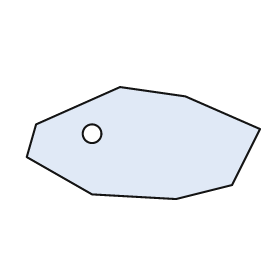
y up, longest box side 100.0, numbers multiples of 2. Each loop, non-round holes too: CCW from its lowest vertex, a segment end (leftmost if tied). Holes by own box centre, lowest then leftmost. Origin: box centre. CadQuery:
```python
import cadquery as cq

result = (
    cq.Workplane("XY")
    .moveTo(14.0, -24.0)
    .lineTo(38.0, -18.0)
    .lineTo(50.0, 6.0)
    .lineTo(18.0, 20.0)
    .lineTo(-10.0, 24.0)
    .lineTo(-46.0, 8.0)
    .lineTo(-50.0, -6.0)
    .lineTo(-22.0, -22.0)
    .close()
    .moveTo(-22.0, 4.0)
    .circle(4.0)
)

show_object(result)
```